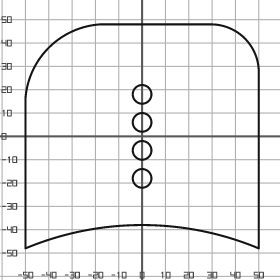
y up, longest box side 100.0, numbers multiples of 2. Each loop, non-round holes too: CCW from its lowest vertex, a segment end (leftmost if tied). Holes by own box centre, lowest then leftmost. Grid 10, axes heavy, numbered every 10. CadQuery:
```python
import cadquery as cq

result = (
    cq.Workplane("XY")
    .moveTo(-50.0, -48.0)
    .threePointArc((0.0, -38.0), (50.0, -48.0))
    .lineTo(50.0, 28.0)
    .threePointArc((44.0, 42.0), (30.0, 48.0))
    .lineTo(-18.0, 48.0)
    .threePointArc((-40.0, 38.0), (-50.0, 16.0))
    .close()
    .moveTo(0.0, -18.0)
    .circle(4.0)
    .moveTo(0.0, -6.0)
    .circle(4.0)
    .moveTo(0.0, 6.0)
    .circle(4.0)
    .moveTo(0.0, 18.0)
    .circle(4.0)
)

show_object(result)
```